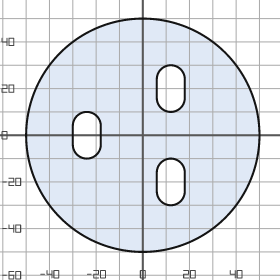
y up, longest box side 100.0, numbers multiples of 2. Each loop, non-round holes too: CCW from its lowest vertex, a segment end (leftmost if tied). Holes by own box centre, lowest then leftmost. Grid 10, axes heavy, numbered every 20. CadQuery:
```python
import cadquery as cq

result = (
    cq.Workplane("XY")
    .moveTo(0.0, 0.0)
    .circle(50.0)
    .moveTo(6.0, -24.0)
    .threePointArc((12.0, -30.0), (18.0, -24.0))
    .lineTo(18.0, -16.0)
    .threePointArc((12.0, -10.0), (6.0, -16.0))
    .close()
    .moveTo(-30.0, -4.0)
    .threePointArc((-24.0, -10.0), (-18.0, -4.0))
    .lineTo(-18.0, 4.0)
    .threePointArc((-24.0, 10.0), (-30.0, 4.0))
    .close()
    .moveTo(6.0, 16.0)
    .threePointArc((12.0, 10.0), (18.0, 16.0))
    .lineTo(18.0, 24.0)
    .threePointArc((12.0, 30.0), (6.0, 24.0))
    .close()
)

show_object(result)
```